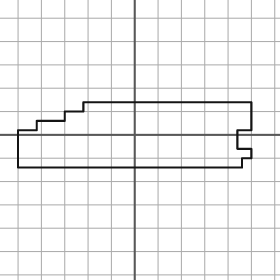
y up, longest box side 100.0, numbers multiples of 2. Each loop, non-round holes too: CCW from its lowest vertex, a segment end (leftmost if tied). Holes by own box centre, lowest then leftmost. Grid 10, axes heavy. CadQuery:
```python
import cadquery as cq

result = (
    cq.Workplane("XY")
    .moveTo(-50.0, -14.0)
    .lineTo(46.0, -14.0)
    .lineTo(46.0, -10.0)
    .lineTo(50.0, -10.0)
    .lineTo(50.0, -6.0)
    .lineTo(44.0, -6.0)
    .lineTo(44.0, 2.0)
    .lineTo(50.0, 2.0)
    .lineTo(50.0, 14.0)
    .lineTo(-22.0, 14.0)
    .lineTo(-22.0, 10.0)
    .lineTo(-30.0, 10.0)
    .lineTo(-30.0, 6.0)
    .lineTo(-42.0, 6.0)
    .lineTo(-42.0, 2.0)
    .lineTo(-50.0, 2.0)
    .close()
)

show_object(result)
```